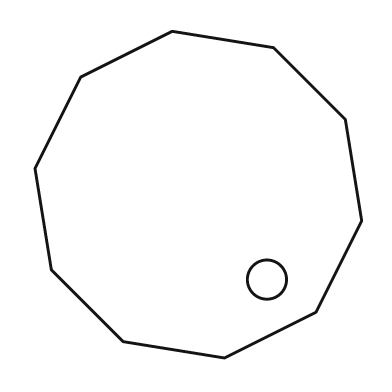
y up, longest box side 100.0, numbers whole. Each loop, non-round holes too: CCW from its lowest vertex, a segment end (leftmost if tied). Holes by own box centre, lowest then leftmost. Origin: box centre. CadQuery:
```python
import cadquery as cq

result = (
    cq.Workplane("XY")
    .moveTo(8.0, -50.0)
    .lineTo(36.0, -36.0)
    .lineTo(50.0, -8.0)
    .lineTo(45.0, 23.0)
    .lineTo(23.0, 45.0)
    .lineTo(-8.0, 50.0)
    .lineTo(-36.0, 36.0)
    .lineTo(-50.0, 8.0)
    .lineTo(-45.0, -23.0)
    .lineTo(-23.0, -45.0)
    .close()
    .moveTo(21.0, -26.0)
    .circle(6.0)
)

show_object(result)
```